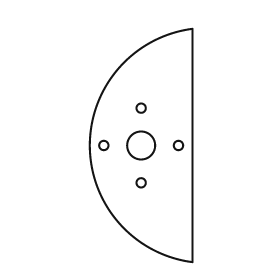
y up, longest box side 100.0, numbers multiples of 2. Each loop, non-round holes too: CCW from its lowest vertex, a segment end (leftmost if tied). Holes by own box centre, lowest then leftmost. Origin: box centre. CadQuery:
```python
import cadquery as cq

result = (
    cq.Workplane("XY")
    .moveTo(22.0, -50.0)
    .lineTo(22.0, 50.0)
    .threePointArc((-22.0, 0.0), (22.0, -50.0))
    .close()
    .moveTo(0.0, -16.0)
    .circle(2.0)
    .moveTo(-16.0, 0.0)
    .circle(2.0)
    .moveTo(0.0, 0.0)
    .circle(6.0)
    .moveTo(16.0, 0.0)
    .circle(2.0)
    .moveTo(0.0, 16.0)
    .circle(2.0)
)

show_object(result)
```